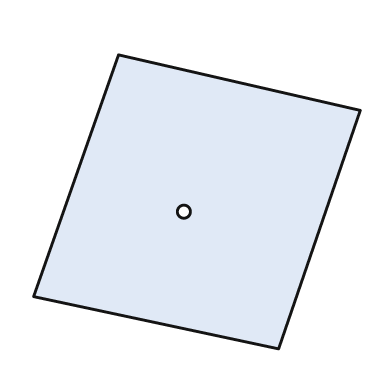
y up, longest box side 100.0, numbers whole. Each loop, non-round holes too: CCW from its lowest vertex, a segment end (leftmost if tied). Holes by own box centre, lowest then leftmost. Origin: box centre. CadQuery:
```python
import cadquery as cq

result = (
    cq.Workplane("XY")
    .moveTo(25.0, -45.0)
    .lineTo(50.0, 28.0)
    .lineTo(-24.0, 45.0)
    .lineTo(-50.0, -29.0)
    .close()
    .moveTo(-4.0, -3.0)
    .circle(2.0)
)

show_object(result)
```